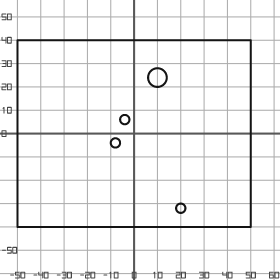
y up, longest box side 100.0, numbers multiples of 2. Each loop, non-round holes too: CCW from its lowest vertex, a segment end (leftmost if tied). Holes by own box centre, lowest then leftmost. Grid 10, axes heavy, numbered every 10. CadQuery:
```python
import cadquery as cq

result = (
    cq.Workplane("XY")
    .moveTo(-50.0, -40.0)
    .lineTo(50.0, -40.0)
    .lineTo(50.0, 40.0)
    .lineTo(-50.0, 40.0)
    .close()
    .moveTo(20.0, -32.0)
    .circle(2.0)
    .moveTo(-8.0, -4.0)
    .circle(2.0)
    .moveTo(-4.0, 6.0)
    .circle(2.0)
    .moveTo(10.0, 24.0)
    .circle(4.0)
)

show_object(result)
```